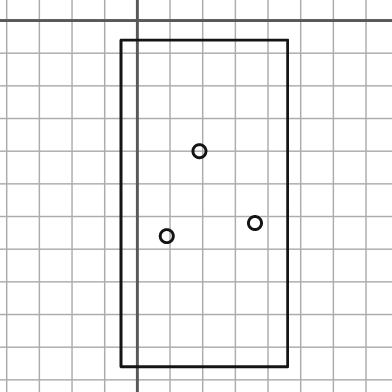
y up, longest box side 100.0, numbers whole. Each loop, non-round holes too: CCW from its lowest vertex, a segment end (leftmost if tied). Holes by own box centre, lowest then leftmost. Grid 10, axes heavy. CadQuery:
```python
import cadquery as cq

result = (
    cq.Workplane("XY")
    .moveTo(-5.0, -106.0)
    .lineTo(46.0, -106.0)
    .lineTo(46.0, -6.0)
    .lineTo(-5.0, -6.0)
    .close()
    .moveTo(9.0, -66.0)
    .circle(2.0)
    .moveTo(36.0, -62.0)
    .circle(2.0)
    .moveTo(19.0, -40.0)
    .circle(2.0)
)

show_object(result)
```